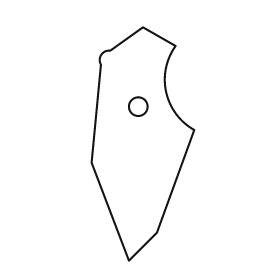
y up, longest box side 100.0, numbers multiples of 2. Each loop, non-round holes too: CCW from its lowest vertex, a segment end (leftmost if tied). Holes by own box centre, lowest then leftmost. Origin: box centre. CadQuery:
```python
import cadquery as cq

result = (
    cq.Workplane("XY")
    .moveTo(-6.0, -50.0)
    .lineTo(6.0, -38.0)
    .lineTo(22.0, 6.0)
    .threePointArc((10.0, 22.0), (14.0, 42.0))
    .lineTo(0.0, 50.0)
    .lineTo(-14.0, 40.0)
    .threePointArc((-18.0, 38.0), (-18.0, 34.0))
    .lineTo(-22.0, -8.0)
    .close()
    .moveTo(-2.0, 16.0)
    .circle(4.0)
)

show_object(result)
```